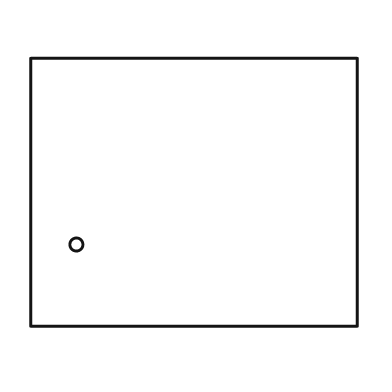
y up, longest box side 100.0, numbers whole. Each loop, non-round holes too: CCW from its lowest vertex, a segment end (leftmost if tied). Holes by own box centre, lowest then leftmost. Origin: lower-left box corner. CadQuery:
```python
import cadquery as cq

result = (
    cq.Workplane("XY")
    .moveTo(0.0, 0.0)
    .lineTo(100.0, 0.0)
    .lineTo(100.0, 82.0)
    .lineTo(0.0, 82.0)
    .close()
    .moveTo(14.0, 25.0)
    .circle(2.0)
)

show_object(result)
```